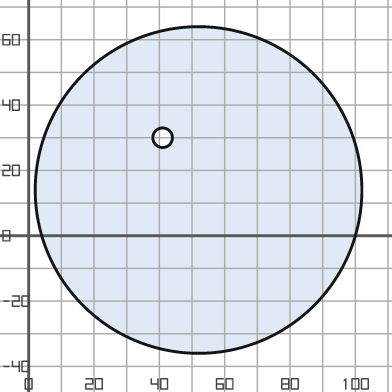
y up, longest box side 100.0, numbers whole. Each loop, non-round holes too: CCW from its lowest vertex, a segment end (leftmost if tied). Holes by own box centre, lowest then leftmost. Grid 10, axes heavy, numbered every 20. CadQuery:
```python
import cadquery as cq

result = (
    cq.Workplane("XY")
    .moveTo(52.0, 14.0)
    .circle(50.0)
    .moveTo(41.0, 30.0)
    .circle(3.0)
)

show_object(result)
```